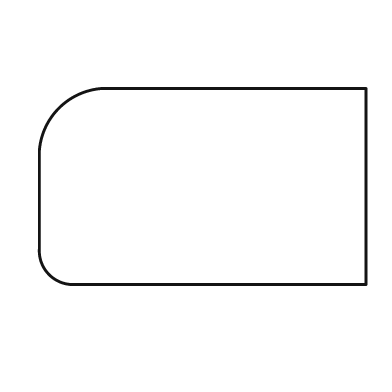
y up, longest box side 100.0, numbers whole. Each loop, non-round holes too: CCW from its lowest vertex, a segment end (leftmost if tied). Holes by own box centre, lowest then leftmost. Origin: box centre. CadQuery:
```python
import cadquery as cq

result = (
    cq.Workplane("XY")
    .moveTo(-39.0, -30.0)
    .lineTo(50.0, -30.0)
    .lineTo(50.0, 30.0)
    .lineTo(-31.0, 30.0)
    .threePointArc((-44.0, 24.0), (-50.0, 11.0))
    .lineTo(-50.0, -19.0)
    .threePointArc((-47.0, -27.0), (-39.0, -30.0))
    .close()
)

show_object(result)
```